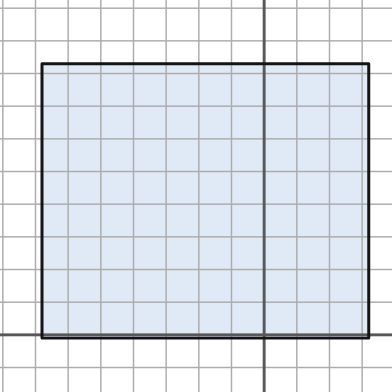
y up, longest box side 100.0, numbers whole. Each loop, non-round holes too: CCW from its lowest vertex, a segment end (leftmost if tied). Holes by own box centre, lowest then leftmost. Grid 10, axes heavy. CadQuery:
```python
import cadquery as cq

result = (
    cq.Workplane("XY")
    .moveTo(-68.0, -1.0)
    .lineTo(32.0, -1.0)
    .lineTo(32.0, 83.0)
    .lineTo(-68.0, 83.0)
    .close()
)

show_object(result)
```